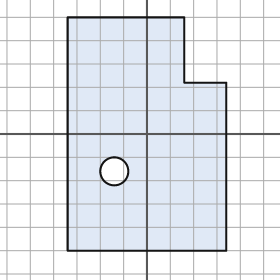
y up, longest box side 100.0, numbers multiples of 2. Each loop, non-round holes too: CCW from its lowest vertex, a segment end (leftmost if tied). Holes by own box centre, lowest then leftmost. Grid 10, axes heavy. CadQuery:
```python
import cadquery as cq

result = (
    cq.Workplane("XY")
    .moveTo(-34.0, -50.0)
    .lineTo(34.0, -50.0)
    .lineTo(34.0, 22.0)
    .lineTo(16.0, 22.0)
    .lineTo(16.0, 50.0)
    .lineTo(-34.0, 50.0)
    .close()
    .moveTo(-14.0, -16.0)
    .circle(6.0)
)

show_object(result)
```